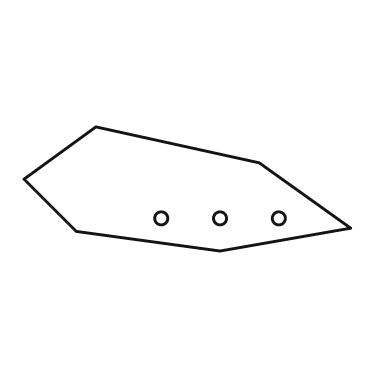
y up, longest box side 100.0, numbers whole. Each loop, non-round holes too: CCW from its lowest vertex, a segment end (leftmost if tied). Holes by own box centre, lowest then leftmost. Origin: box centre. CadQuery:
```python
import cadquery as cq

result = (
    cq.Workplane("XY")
    .moveTo(10.0, -19.0)
    .lineTo(50.0, -12.0)
    .lineTo(22.0, 8.0)
    .lineTo(-28.0, 19.0)
    .lineTo(-50.0, 3.0)
    .lineTo(-34.0, -13.0)
    .close()
    .moveTo(-8.0, -9.0)
    .circle(2.0)
    .moveTo(10.0, -9.0)
    .circle(2.0)
    .moveTo(28.0, -9.0)
    .circle(2.0)
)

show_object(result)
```